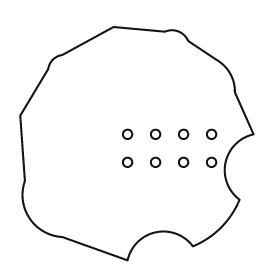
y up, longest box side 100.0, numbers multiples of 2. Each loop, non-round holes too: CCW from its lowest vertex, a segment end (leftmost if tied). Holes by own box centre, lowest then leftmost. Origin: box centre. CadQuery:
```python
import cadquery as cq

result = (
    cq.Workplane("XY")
    .moveTo(-4.0, -50.0)
    .threePointArc((8.0, -38.0), (24.0, -44.0))
    .threePointArc((36.0, -36.0), (44.0, -24.0))
    .threePointArc((38.0, -8.0), (50.0, 4.0))
    .lineTo(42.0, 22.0)
    .threePointArc((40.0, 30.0), (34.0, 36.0))
    .lineTo(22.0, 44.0)
    .threePointArc((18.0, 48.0), (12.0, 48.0))
    .lineTo(-10.0, 50.0)
    .lineTo(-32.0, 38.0)
    .threePointArc((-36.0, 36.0), (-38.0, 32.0))
    .lineTo(-50.0, 12.0)
    .lineTo(-48.0, -16.0)
    .threePointArc((-46.0, -32.0), (-32.0, -40.0))
    .close()
    .moveTo(-4.0, -8.0)
    .circle(2.0)
    .moveTo(8.0, -8.0)
    .circle(2.0)
    .moveTo(20.0, -8.0)
    .circle(2.0)
    .moveTo(32.0, -8.0)
    .circle(2.0)
    .moveTo(-4.0, 4.0)
    .circle(2.0)
    .moveTo(8.0, 4.0)
    .circle(2.0)
    .moveTo(20.0, 4.0)
    .circle(2.0)
    .moveTo(32.0, 4.0)
    .circle(2.0)
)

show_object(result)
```